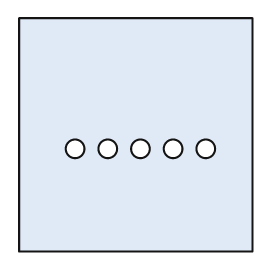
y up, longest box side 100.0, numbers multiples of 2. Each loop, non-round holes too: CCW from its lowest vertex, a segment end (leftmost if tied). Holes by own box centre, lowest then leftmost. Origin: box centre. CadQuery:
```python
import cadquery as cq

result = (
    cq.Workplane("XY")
    .moveTo(-50.0, -50.0)
    .lineTo(50.0, -50.0)
    .lineTo(50.0, 50.0)
    .lineTo(-50.0, 50.0)
    .close()
    .moveTo(-26.0, -6.0)
    .circle(4.0)
    .moveTo(-12.0, -6.0)
    .circle(4.0)
    .moveTo(2.0, -6.0)
    .circle(4.0)
    .moveTo(16.0, -6.0)
    .circle(4.0)
    .moveTo(30.0, -6.0)
    .circle(4.0)
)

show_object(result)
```